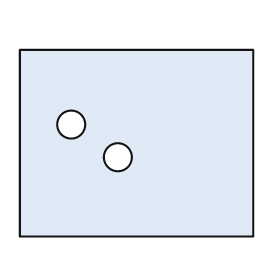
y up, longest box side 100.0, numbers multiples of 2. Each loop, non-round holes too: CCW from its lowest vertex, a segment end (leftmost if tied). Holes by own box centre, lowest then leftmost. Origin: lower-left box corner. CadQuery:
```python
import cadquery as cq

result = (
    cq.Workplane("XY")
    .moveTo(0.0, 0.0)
    .lineTo(100.0, 0.0)
    .lineTo(100.0, 80.0)
    .lineTo(0.0, 80.0)
    .close()
    .moveTo(42.0, 34.0)
    .circle(6.0)
    .moveTo(22.0, 48.0)
    .circle(6.0)
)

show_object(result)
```